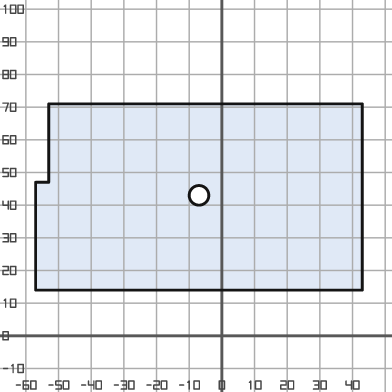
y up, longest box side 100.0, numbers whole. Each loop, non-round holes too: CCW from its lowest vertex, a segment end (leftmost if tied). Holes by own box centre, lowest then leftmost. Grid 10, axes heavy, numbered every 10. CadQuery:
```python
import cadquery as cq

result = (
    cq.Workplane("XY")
    .moveTo(-57.0, 14.0)
    .lineTo(43.0, 14.0)
    .lineTo(43.0, 71.0)
    .lineTo(-53.0, 71.0)
    .lineTo(-53.0, 47.0)
    .lineTo(-57.0, 47.0)
    .close()
    .moveTo(-7.0, 43.0)
    .circle(3.0)
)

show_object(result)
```